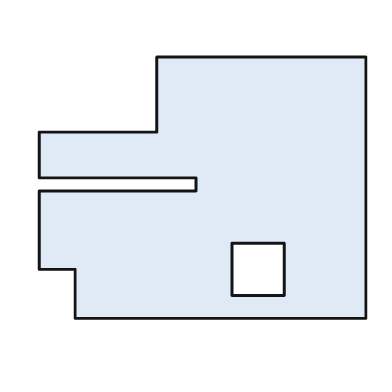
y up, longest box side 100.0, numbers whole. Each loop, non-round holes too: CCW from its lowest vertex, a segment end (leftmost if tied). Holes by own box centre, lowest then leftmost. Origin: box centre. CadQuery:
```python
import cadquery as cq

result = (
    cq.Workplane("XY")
    .moveTo(-39.0, -40.0)
    .lineTo(50.0, -40.0)
    .lineTo(50.0, 40.0)
    .lineTo(-14.0, 40.0)
    .lineTo(-14.0, 17.0)
    .lineTo(-50.0, 17.0)
    .lineTo(-50.0, 3.0)
    .lineTo(-2.0, 3.0)
    .lineTo(-2.0, -1.0)
    .lineTo(-50.0, -1.0)
    .lineTo(-50.0, -25.0)
    .lineTo(-39.0, -25.0)
    .close()
    .moveTo(9.0, -33.0)
    .lineTo(25.0, -33.0)
    .lineTo(25.0, -17.0)
    .lineTo(9.0, -17.0)
    .close()
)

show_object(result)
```